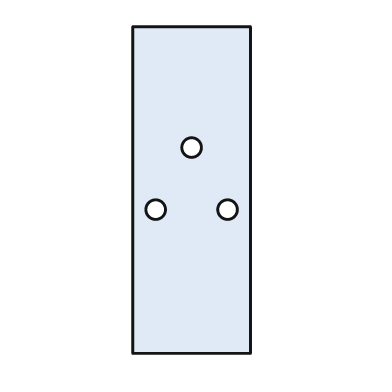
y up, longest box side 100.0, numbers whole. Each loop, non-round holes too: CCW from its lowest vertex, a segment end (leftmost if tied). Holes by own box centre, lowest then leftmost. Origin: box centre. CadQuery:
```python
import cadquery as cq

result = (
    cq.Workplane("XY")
    .moveTo(-18.0, -50.0)
    .lineTo(18.0, -50.0)
    .lineTo(18.0, 50.0)
    .lineTo(-18.0, 50.0)
    .close()
    .moveTo(-11.0, -6.0)
    .circle(3.0)
    .moveTo(11.0, -6.0)
    .circle(3.0)
    .moveTo(0.0, 13.0)
    .circle(3.0)
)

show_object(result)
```